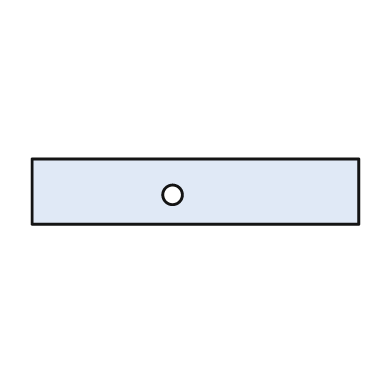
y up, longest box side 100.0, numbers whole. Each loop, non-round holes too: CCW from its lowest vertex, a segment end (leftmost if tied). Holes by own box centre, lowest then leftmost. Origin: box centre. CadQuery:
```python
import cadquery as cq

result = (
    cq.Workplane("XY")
    .moveTo(-50.0, -10.0)
    .lineTo(50.0, -10.0)
    .lineTo(50.0, 10.0)
    .lineTo(-50.0, 10.0)
    .close()
    .moveTo(-7.0, -1.0)
    .circle(3.0)
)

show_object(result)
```